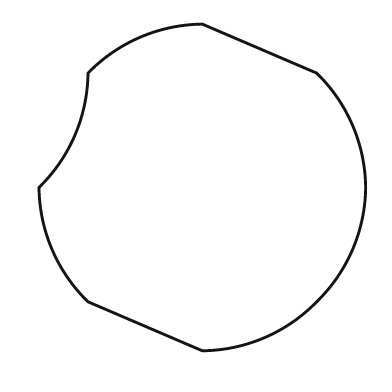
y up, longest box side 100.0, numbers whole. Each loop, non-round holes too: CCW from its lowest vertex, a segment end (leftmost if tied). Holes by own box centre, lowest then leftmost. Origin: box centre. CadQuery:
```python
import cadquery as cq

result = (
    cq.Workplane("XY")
    .moveTo(0.0, -50.0)
    .threePointArc((19.0, -46.0), (35.0, -35.0))
    .threePointArc((46.0, -19.0), (50.0, 0.0))
    .threePointArc((46.0, 19.0), (35.0, 35.0))
    .lineTo(0.0, 50.0)
    .threePointArc((-19.0, 46.0), (-35.0, 35.0))
    .threePointArc((-39.0, 16.0), (-50.0, 0.0))
    .threePointArc((-46.0, -19.0), (-35.0, -35.0))
    .close()
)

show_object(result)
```